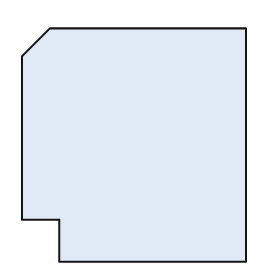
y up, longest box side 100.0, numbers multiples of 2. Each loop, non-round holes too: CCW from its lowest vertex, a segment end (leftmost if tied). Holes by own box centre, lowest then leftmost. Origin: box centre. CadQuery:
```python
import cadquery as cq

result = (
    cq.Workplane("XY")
    .moveTo(-32.0, -50.0)
    .lineTo(48.0, -50.0)
    .lineTo(48.0, 50.0)
    .lineTo(-36.0, 50.0)
    .lineTo(-48.0, 38.0)
    .lineTo(-48.0, -32.0)
    .lineTo(-32.0, -32.0)
    .close()
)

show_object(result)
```